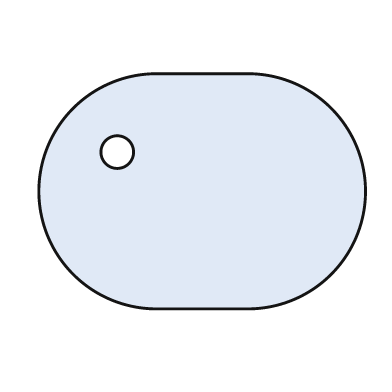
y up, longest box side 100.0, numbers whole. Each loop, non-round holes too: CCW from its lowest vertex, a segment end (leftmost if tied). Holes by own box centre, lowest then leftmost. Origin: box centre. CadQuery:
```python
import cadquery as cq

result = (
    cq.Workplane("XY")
    .moveTo(-14.0, -36.0)
    .lineTo(14.0, -36.0)
    .threePointArc((50.0, 0.0), (14.0, 36.0))
    .lineTo(-14.0, 36.0)
    .threePointArc((-50.0, 0.0), (-14.0, -36.0))
    .close()
    .moveTo(-26.0, 12.0)
    .circle(5.0)
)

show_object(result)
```